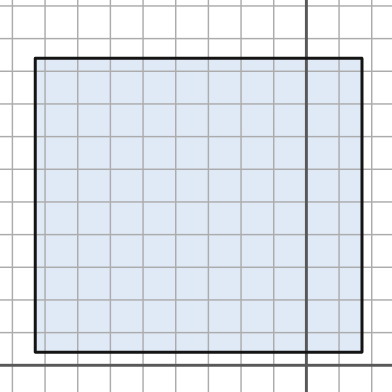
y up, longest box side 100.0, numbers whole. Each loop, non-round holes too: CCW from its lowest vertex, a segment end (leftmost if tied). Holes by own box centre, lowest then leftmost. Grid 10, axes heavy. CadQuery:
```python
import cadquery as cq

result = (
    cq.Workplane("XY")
    .moveTo(-83.0, 4.0)
    .lineTo(17.0, 4.0)
    .lineTo(17.0, 94.0)
    .lineTo(-83.0, 94.0)
    .close()
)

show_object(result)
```